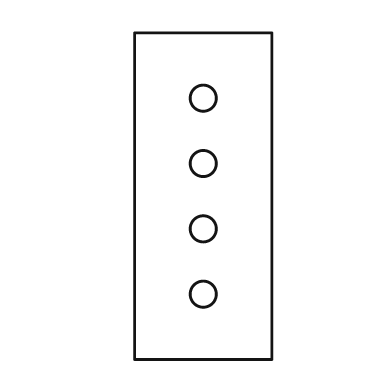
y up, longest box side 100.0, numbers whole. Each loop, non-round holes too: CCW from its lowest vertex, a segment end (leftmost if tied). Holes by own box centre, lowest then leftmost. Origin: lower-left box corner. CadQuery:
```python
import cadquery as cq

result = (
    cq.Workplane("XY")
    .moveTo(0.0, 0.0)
    .lineTo(42.0, 0.0)
    .lineTo(42.0, 100.0)
    .lineTo(0.0, 100.0)
    .close()
    .moveTo(21.0, 20.0)
    .circle(4.0)
    .moveTo(21.0, 40.0)
    .circle(4.0)
    .moveTo(21.0, 60.0)
    .circle(4.0)
    .moveTo(21.0, 80.0)
    .circle(4.0)
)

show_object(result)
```